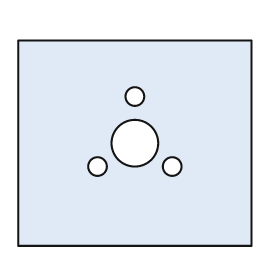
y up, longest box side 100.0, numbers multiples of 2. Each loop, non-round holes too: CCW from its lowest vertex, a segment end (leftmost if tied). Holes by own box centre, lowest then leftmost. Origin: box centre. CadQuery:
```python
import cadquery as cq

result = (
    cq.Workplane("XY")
    .moveTo(-50.0, -44.0)
    .lineTo(50.0, -44.0)
    .lineTo(50.0, 44.0)
    .lineTo(-50.0, 44.0)
    .close()
    .moveTo(-16.0, -10.0)
    .circle(4.0)
    .moveTo(16.0, -10.0)
    .circle(4.0)
    .moveTo(0.0, 0.0)
    .circle(10.0)
    .moveTo(0.0, 20.0)
    .circle(4.0)
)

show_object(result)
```